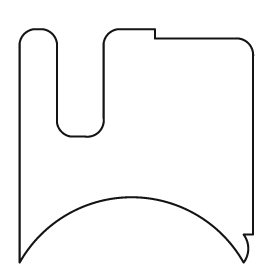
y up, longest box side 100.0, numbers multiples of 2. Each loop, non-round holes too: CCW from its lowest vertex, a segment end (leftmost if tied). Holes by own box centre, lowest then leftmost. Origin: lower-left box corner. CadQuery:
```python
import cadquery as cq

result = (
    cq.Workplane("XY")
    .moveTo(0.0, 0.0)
    .threePointArc((48.0, 28.0), (96.0, 0.0))
    .threePointArc((98.0, 6.0), (96.0, 12.0))
    .lineTo(100.0, 12.0)
    .lineTo(100.0, 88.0)
    .threePointArc((98.0, 94.0), (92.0, 96.0))
    .lineTo(58.0, 96.0)
    .lineTo(58.0, 100.0)
    .lineTo(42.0, 100.0)
    .threePointArc((38.0, 98.0), (36.0, 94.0))
    .lineTo(36.0, 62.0)
    .threePointArc((34.0, 56.0), (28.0, 54.0))
    .lineTo(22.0, 54.0)
    .threePointArc((18.0, 56.0), (16.0, 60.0))
    .lineTo(16.0, 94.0)
    .threePointArc((14.0, 98.0), (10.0, 100.0))
    .lineTo(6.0, 100.0)
    .threePointArc((2.0, 98.0), (0.0, 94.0))
    .close()
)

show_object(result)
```